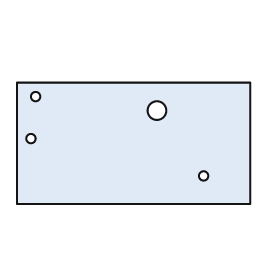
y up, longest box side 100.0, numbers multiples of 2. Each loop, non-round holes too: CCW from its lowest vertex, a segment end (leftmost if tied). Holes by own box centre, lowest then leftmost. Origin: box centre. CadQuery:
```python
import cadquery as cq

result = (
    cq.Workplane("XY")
    .moveTo(-50.0, -26.0)
    .lineTo(50.0, -26.0)
    .lineTo(50.0, 26.0)
    .lineTo(-50.0, 26.0)
    .close()
    .moveTo(30.0, -14.0)
    .circle(2.0)
    .moveTo(-44.0, 2.0)
    .circle(2.0)
    .moveTo(10.0, 14.0)
    .circle(4.0)
    .moveTo(-42.0, 20.0)
    .circle(2.0)
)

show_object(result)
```